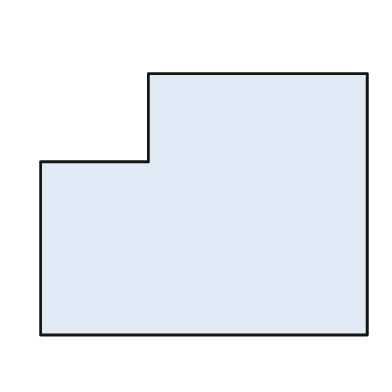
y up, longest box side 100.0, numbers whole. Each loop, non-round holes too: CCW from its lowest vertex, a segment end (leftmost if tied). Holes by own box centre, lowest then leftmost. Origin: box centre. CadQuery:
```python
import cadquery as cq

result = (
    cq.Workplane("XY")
    .moveTo(-50.0, -40.0)
    .lineTo(50.0, -40.0)
    .lineTo(50.0, 40.0)
    .lineTo(-17.0, 40.0)
    .lineTo(-17.0, 13.0)
    .lineTo(-50.0, 13.0)
    .close()
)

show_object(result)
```